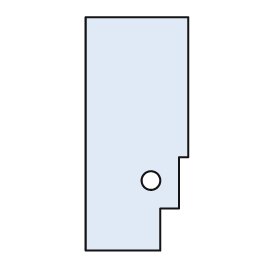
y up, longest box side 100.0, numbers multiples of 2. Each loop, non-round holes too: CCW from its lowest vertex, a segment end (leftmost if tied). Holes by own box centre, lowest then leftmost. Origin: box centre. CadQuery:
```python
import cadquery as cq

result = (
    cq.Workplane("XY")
    .moveTo(-22.0, -50.0)
    .lineTo(10.0, -50.0)
    .lineTo(10.0, -32.0)
    .lineTo(18.0, -32.0)
    .lineTo(18.0, -10.0)
    .lineTo(22.0, -10.0)
    .lineTo(22.0, 50.0)
    .lineTo(-22.0, 50.0)
    .close()
    .moveTo(6.0, -20.0)
    .circle(4.0)
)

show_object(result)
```